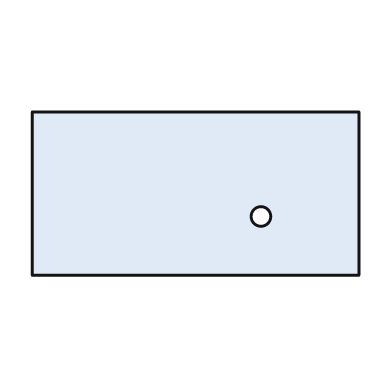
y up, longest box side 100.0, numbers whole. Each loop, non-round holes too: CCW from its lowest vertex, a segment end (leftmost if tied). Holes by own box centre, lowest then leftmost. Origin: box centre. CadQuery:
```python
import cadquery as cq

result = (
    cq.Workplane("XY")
    .moveTo(-50.0, -25.0)
    .lineTo(50.0, -25.0)
    .lineTo(50.0, 25.0)
    .lineTo(-50.0, 25.0)
    .close()
    .moveTo(20.0, -7.0)
    .circle(3.0)
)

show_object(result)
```